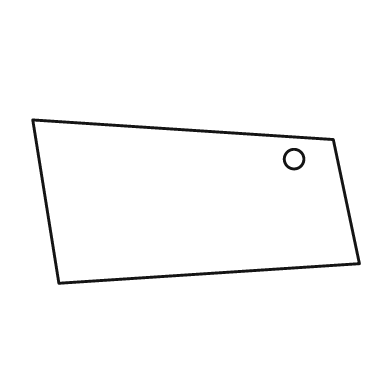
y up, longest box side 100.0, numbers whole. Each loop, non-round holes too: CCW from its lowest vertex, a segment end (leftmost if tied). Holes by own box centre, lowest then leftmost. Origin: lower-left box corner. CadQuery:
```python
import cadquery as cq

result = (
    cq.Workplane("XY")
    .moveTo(8.0, 0.0)
    .lineTo(100.0, 6.0)
    .lineTo(92.0, 44.0)
    .lineTo(0.0, 50.0)
    .close()
    .moveTo(80.0, 38.0)
    .circle(3.0)
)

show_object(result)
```